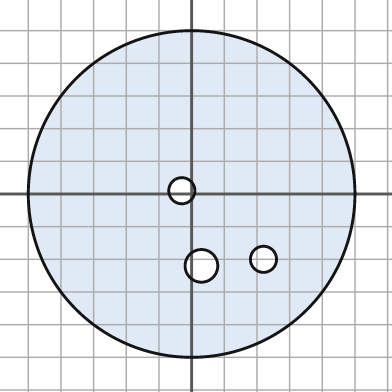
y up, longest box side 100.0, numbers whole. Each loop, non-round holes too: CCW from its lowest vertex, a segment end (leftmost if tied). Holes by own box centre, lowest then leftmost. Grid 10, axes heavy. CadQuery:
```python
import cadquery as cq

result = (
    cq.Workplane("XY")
    .moveTo(0.0, 0.0)
    .circle(50.0)
    .moveTo(3.0, -22.0)
    .circle(5.0)
    .moveTo(22.0, -20.0)
    .circle(4.0)
    .moveTo(-3.0, 1.0)
    .circle(4.0)
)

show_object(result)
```